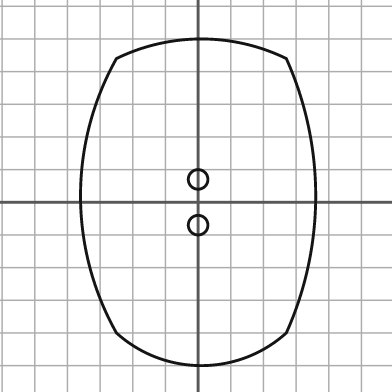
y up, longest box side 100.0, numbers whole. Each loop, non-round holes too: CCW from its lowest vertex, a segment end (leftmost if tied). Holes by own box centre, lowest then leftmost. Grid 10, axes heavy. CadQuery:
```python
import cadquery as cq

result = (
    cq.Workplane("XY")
    .moveTo(-25.0, -40.0)
    .threePointArc((1.0, -50.0), (27.0, -40.0))
    .threePointArc((36.0, 2.0), (27.0, 44.0))
    .threePointArc((1.0, 50.0), (-25.0, 44.0))
    .threePointArc((-36.0, 2.0), (-25.0, -40.0))
    .close()
    .moveTo(0.0, -7.0)
    .circle(3.0)
    .moveTo(0.0, 7.0)
    .circle(3.0)
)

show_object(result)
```